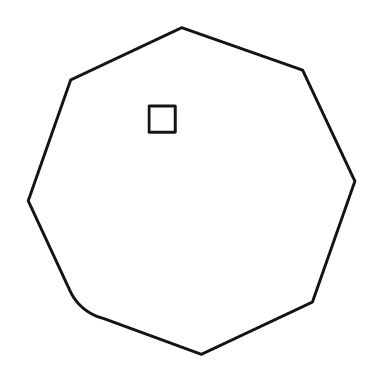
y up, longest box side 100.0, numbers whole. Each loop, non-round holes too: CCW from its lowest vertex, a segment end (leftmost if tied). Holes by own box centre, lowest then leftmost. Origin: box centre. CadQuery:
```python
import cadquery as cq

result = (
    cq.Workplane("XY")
    .moveTo(3.0, -50.0)
    .lineTo(37.0, -34.0)
    .lineTo(50.0, 3.0)
    .lineTo(34.0, 37.0)
    .lineTo(-3.0, 50.0)
    .lineTo(-37.0, 34.0)
    .lineTo(-50.0, -3.0)
    .lineTo(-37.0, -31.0)
    .threePointArc((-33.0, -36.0), (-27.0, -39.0))
    .close()
    .moveTo(-13.0, 18.0)
    .lineTo(-5.0, 18.0)
    .lineTo(-5.0, 26.0)
    .lineTo(-13.0, 26.0)
    .close()
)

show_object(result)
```